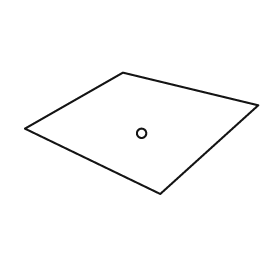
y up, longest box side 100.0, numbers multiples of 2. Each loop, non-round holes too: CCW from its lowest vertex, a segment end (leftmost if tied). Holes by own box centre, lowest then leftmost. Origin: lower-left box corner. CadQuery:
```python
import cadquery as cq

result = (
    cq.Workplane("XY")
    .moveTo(58.0, 0.0)
    .lineTo(100.0, 38.0)
    .lineTo(42.0, 52.0)
    .lineTo(0.0, 28.0)
    .close()
    .moveTo(50.0, 26.0)
    .circle(2.0)
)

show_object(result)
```